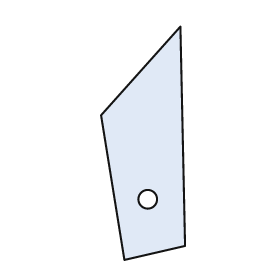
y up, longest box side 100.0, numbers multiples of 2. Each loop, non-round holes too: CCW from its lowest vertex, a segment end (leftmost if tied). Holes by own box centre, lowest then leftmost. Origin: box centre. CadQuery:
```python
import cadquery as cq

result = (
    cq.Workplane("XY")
    .moveTo(-8.0, -50.0)
    .lineTo(18.0, -44.0)
    .lineTo(16.0, 50.0)
    .lineTo(-18.0, 12.0)
    .close()
    .moveTo(2.0, -24.0)
    .circle(4.0)
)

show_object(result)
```